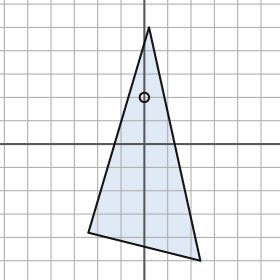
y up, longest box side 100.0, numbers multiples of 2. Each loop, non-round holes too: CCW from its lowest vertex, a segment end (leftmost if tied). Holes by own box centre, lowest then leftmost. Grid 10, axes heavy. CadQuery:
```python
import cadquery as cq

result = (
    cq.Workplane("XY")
    .moveTo(24.0, -50.0)
    .lineTo(2.0, 50.0)
    .lineTo(-24.0, -38.0)
    .close()
    .moveTo(0.0, 20.0)
    .circle(2.0)
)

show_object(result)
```